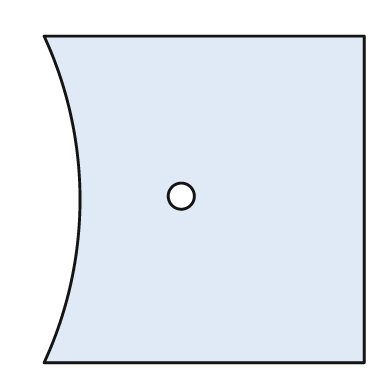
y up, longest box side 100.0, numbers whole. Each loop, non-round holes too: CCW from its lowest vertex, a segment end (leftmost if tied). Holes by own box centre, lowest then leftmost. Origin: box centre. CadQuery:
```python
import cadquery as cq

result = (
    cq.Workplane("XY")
    .moveTo(-49.0, -50.0)
    .lineTo(49.0, -50.0)
    .lineTo(49.0, 50.0)
    .lineTo(-49.0, 50.0)
    .threePointArc((-38.0, 0.0), (-49.0, -50.0))
    .close()
    .moveTo(-7.0, 1.0)
    .circle(4.0)
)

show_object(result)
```